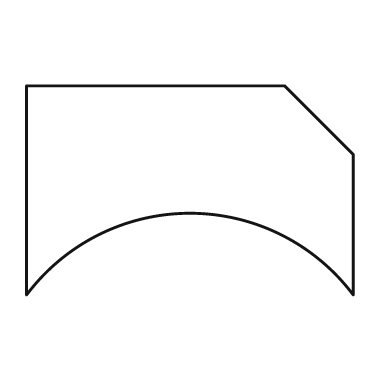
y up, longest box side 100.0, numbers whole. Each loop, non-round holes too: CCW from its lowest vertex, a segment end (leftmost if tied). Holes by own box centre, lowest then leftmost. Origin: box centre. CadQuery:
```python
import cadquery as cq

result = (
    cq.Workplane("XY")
    .moveTo(-50.0, -32.0)
    .threePointArc((0.0, -7.0), (50.0, -32.0))
    .lineTo(50.0, 11.0)
    .lineTo(29.0, 32.0)
    .lineTo(-50.0, 32.0)
    .close()
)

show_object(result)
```